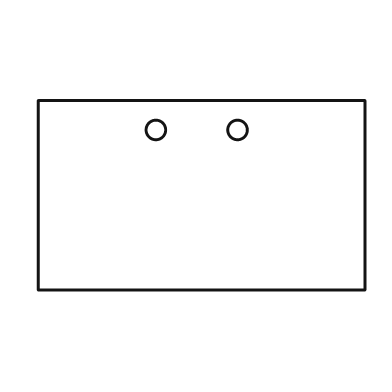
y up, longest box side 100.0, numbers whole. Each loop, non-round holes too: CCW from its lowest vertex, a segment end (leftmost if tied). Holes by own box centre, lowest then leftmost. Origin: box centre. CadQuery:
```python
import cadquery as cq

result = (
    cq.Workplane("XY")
    .moveTo(-50.0, -29.0)
    .lineTo(50.0, -29.0)
    .lineTo(50.0, 29.0)
    .lineTo(-50.0, 29.0)
    .close()
    .moveTo(-14.0, 20.0)
    .circle(3.0)
    .moveTo(11.0, 20.0)
    .circle(3.0)
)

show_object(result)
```